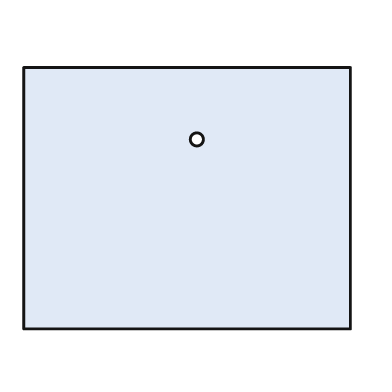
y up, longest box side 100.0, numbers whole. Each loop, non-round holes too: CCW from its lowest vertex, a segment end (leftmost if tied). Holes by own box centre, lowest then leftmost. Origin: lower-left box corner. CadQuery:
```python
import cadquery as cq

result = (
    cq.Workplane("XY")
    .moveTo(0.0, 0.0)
    .lineTo(100.0, 0.0)
    .lineTo(100.0, 80.0)
    .lineTo(0.0, 80.0)
    .close()
    .moveTo(53.0, 58.0)
    .circle(2.0)
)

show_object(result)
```